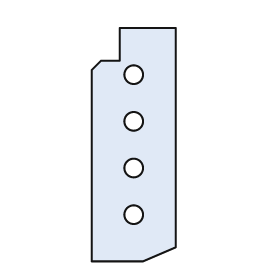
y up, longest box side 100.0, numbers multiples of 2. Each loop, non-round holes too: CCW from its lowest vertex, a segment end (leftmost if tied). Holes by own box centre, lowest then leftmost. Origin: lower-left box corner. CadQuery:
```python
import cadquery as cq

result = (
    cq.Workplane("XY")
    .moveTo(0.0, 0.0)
    .lineTo(22.0, 0.0)
    .lineTo(36.0, 6.0)
    .lineTo(36.0, 100.0)
    .lineTo(12.0, 100.0)
    .lineTo(12.0, 86.0)
    .lineTo(4.0, 86.0)
    .lineTo(0.0, 82.0)
    .close()
    .moveTo(18.0, 20.0)
    .circle(4.0)
    .moveTo(18.0, 40.0)
    .circle(4.0)
    .moveTo(18.0, 60.0)
    .circle(4.0)
    .moveTo(18.0, 80.0)
    .circle(4.0)
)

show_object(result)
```